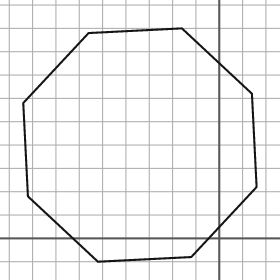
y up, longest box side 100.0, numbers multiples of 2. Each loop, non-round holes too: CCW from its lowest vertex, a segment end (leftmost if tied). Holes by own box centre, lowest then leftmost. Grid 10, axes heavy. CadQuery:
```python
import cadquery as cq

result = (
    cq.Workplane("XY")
    .moveTo(-52.0, -10.0)
    .lineTo(-12.0, -8.0)
    .lineTo(16.0, 22.0)
    .lineTo(14.0, 62.0)
    .lineTo(-16.0, 90.0)
    .lineTo(-56.0, 88.0)
    .lineTo(-84.0, 58.0)
    .lineTo(-82.0, 18.0)
    .close()
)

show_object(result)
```